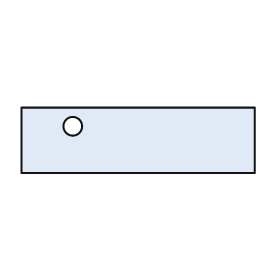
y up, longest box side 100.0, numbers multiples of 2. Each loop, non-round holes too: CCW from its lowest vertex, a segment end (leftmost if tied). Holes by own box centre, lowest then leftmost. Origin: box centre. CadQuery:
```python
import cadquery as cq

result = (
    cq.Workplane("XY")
    .moveTo(-50.0, -14.0)
    .lineTo(50.0, -14.0)
    .lineTo(50.0, 14.0)
    .lineTo(-50.0, 14.0)
    .close()
    .moveTo(-28.0, 6.0)
    .circle(4.0)
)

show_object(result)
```